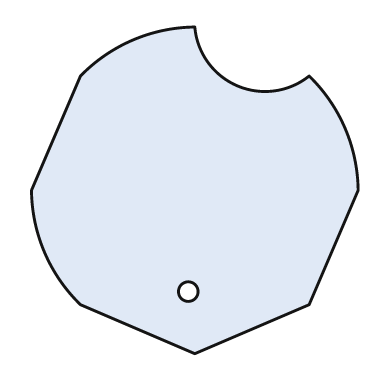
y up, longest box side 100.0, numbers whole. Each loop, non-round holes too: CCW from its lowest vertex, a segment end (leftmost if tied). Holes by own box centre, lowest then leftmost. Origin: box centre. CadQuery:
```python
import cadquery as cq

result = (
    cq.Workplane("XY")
    .moveTo(0.0, -50.0)
    .lineTo(35.0, -35.0)
    .lineTo(50.0, 0.0)
    .threePointArc((46.0, 19.0), (35.0, 35.0))
    .threePointArc((13.0, 32.0), (0.0, 50.0))
    .threePointArc((-19.0, 46.0), (-35.0, 35.0))
    .lineTo(-50.0, 0.0)
    .threePointArc((-46.0, -19.0), (-35.0, -35.0))
    .close()
    .moveTo(-2.0, -31.0)
    .circle(3.0)
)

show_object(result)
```